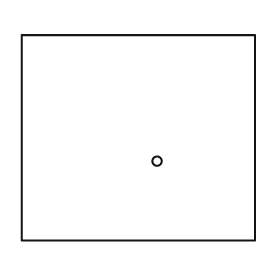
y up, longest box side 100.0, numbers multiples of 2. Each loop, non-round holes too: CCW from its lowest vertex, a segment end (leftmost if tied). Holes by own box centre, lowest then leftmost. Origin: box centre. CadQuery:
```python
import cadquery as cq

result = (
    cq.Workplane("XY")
    .moveTo(-50.0, -44.0)
    .lineTo(50.0, -44.0)
    .lineTo(50.0, 44.0)
    .lineTo(-50.0, 44.0)
    .close()
    .moveTo(8.0, -10.0)
    .circle(2.0)
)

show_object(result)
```